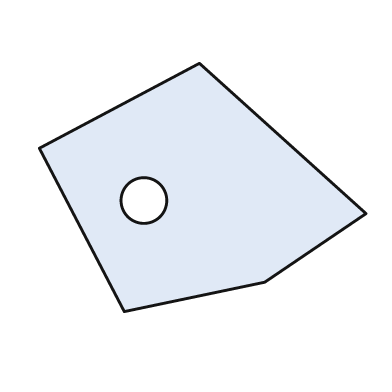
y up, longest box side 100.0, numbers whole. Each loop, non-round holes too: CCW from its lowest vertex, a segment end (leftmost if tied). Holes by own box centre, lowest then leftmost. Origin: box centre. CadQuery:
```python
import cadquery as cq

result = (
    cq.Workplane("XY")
    .moveTo(-24.0, -38.0)
    .lineTo(19.0, -29.0)
    .lineTo(50.0, -8.0)
    .lineTo(-1.0, 38.0)
    .lineTo(-50.0, 12.0)
    .close()
    .moveTo(-18.0, -4.0)
    .circle(7.0)
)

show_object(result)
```